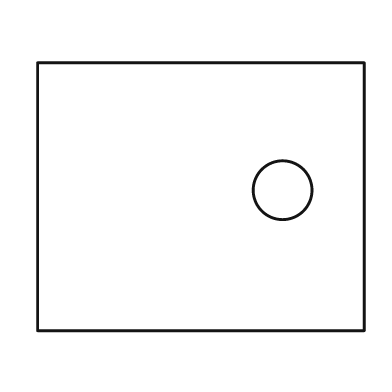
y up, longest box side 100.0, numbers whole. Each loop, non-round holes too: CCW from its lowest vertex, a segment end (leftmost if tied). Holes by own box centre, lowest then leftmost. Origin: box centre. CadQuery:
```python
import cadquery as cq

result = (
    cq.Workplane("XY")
    .moveTo(-50.0, -41.0)
    .lineTo(50.0, -41.0)
    .lineTo(50.0, 41.0)
    .lineTo(-50.0, 41.0)
    .close()
    .moveTo(25.0, 2.0)
    .circle(9.0)
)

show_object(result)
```